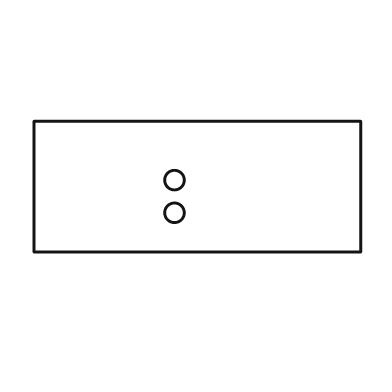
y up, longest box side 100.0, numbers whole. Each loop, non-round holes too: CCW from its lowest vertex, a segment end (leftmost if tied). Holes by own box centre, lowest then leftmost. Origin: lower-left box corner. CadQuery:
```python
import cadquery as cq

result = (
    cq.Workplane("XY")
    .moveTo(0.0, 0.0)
    .lineTo(100.0, 0.0)
    .lineTo(100.0, 40.0)
    .lineTo(0.0, 40.0)
    .close()
    .moveTo(43.0, 12.0)
    .circle(3.0)
    .moveTo(43.0, 22.0)
    .circle(3.0)
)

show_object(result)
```